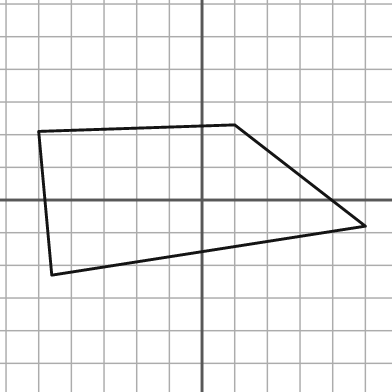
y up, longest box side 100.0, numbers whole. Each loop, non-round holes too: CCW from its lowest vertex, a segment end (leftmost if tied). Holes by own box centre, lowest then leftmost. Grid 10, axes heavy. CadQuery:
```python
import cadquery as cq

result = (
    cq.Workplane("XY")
    .moveTo(-46.0, -23.0)
    .lineTo(50.0, -8.0)
    .lineTo(10.0, 23.0)
    .lineTo(-50.0, 21.0)
    .close()
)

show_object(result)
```